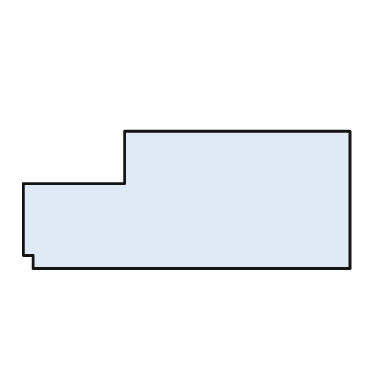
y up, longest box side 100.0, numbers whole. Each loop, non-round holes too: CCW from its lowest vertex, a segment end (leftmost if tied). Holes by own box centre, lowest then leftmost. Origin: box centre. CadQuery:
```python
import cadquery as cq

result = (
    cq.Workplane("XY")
    .moveTo(-47.0, -21.0)
    .lineTo(50.0, -21.0)
    .lineTo(50.0, 21.0)
    .lineTo(-19.0, 21.0)
    .lineTo(-19.0, 5.0)
    .lineTo(-50.0, 5.0)
    .lineTo(-50.0, -17.0)
    .lineTo(-47.0, -17.0)
    .close()
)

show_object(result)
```